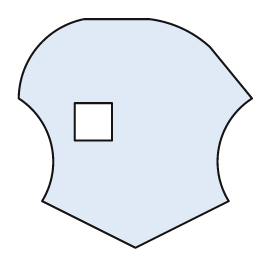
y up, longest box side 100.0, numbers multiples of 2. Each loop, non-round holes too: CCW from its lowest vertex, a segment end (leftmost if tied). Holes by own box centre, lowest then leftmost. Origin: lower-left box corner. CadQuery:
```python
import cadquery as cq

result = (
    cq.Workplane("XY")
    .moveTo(50.0, 0.0)
    .lineTo(90.0, 20.0)
    .threePointArc((86.0, 44.0), (100.0, 64.0))
    .lineTo(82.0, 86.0)
    .threePointArc((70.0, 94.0), (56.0, 98.0))
    .lineTo(28.0, 98.0)
    .threePointArc((8.0, 86.0), (0.0, 64.0))
    .threePointArc((14.0, 44.0), (10.0, 20.0))
    .close()
    .moveTo(24.0, 46.0)
    .lineTo(40.0, 46.0)
    .lineTo(40.0, 62.0)
    .lineTo(24.0, 62.0)
    .close()
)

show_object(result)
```